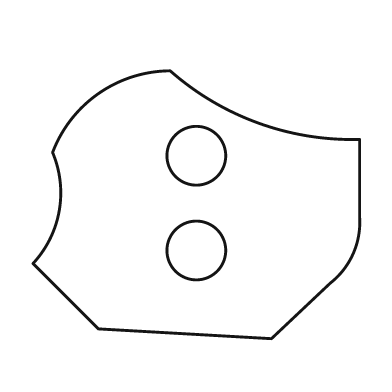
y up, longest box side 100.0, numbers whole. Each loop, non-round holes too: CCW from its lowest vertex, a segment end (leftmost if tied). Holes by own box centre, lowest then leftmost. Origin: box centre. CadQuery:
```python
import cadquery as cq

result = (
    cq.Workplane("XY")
    .moveTo(23.0, -41.0)
    .lineTo(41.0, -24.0)
    .threePointArc((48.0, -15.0), (50.0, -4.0))
    .lineTo(50.0, 20.0)
    .threePointArc((19.0, 25.0), (-8.0, 41.0))
    .threePointArc((-30.0, 34.0), (-44.0, 16.0))
    .threePointArc((-42.0, -2.0), (-50.0, -18.0))
    .lineTo(-30.0, -38.0)
    .close()
    .moveTo(0.0, -14.0)
    .circle(9.0)
    .moveTo(0.0, 15.0)
    .circle(9.0)
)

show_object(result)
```